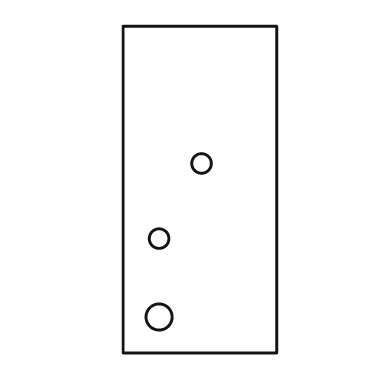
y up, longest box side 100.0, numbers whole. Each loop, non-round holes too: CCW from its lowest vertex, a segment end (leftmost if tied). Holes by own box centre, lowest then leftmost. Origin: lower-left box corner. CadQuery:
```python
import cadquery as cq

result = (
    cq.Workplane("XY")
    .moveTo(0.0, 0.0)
    .lineTo(47.0, 0.0)
    .lineTo(47.0, 100.0)
    .lineTo(0.0, 100.0)
    .close()
    .moveTo(11.0, 11.0)
    .circle(4.0)
    .moveTo(11.0, 35.0)
    .circle(3.0)
    .moveTo(24.0, 58.0)
    .circle(3.0)
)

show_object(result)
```